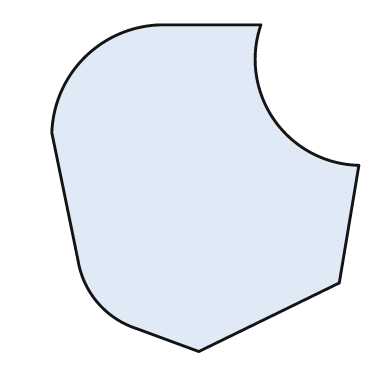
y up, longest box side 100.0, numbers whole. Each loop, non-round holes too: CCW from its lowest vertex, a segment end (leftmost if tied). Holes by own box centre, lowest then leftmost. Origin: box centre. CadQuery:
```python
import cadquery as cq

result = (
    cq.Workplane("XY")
    .moveTo(-2.0, -50.0)
    .lineTo(41.0, -29.0)
    .lineTo(47.0, 7.0)
    .threePointArc((21.0, 21.0), (17.0, 50.0))
    .lineTo(-14.0, 50.0)
    .threePointArc((-37.0, 40.0), (-47.0, 17.0))
    .lineTo(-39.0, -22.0)
    .threePointArc((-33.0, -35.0), (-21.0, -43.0))
    .close()
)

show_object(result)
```